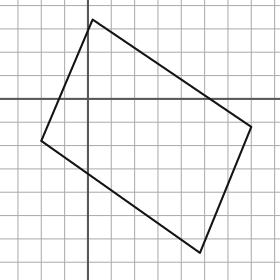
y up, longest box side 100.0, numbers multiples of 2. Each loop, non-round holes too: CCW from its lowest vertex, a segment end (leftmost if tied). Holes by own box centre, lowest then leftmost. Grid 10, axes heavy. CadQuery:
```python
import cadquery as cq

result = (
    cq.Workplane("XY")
    .moveTo(48.0, -66.0)
    .lineTo(70.0, -12.0)
    .lineTo(2.0, 34.0)
    .lineTo(-20.0, -18.0)
    .close()
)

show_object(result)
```